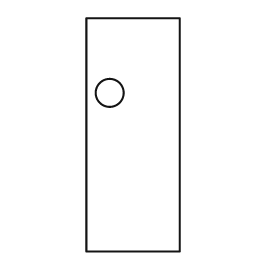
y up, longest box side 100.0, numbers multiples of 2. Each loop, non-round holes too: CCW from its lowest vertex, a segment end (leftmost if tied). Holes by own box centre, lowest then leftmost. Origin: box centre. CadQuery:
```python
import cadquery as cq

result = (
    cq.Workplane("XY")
    .moveTo(-20.0, -50.0)
    .lineTo(20.0, -50.0)
    .lineTo(20.0, 50.0)
    .lineTo(-20.0, 50.0)
    .close()
    .moveTo(-10.0, 18.0)
    .circle(6.0)
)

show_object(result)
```